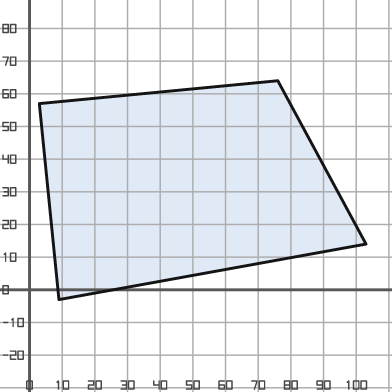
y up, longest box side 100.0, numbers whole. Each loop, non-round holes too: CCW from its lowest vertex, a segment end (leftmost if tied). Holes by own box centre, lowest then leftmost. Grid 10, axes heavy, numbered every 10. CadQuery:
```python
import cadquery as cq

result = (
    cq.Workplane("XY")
    .moveTo(9.0, -3.0)
    .lineTo(103.0, 14.0)
    .lineTo(76.0, 64.0)
    .lineTo(3.0, 57.0)
    .close()
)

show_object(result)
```